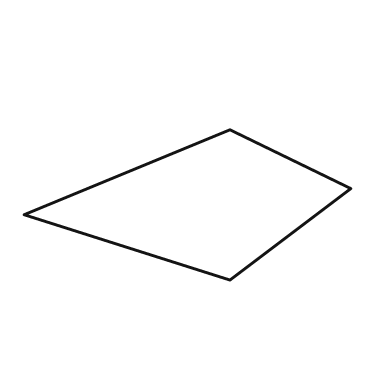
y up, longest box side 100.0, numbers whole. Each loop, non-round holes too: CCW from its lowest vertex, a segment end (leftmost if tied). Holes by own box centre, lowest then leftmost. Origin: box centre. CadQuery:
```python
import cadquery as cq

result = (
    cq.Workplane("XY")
    .moveTo(13.0, -23.0)
    .lineTo(50.0, 5.0)
    .lineTo(13.0, 23.0)
    .lineTo(-50.0, -3.0)
    .close()
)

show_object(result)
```